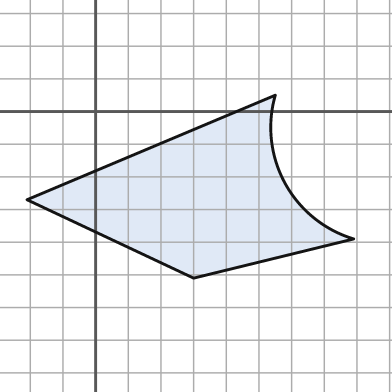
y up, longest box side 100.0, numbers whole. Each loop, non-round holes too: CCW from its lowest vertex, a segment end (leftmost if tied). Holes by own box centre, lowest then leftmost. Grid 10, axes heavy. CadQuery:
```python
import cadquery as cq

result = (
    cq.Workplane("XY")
    .moveTo(30.0, -51.0)
    .lineTo(79.0, -39.0)
    .threePointArc((58.0, -22.0), (55.0, 5.0))
    .lineTo(-21.0, -27.0)
    .close()
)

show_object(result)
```